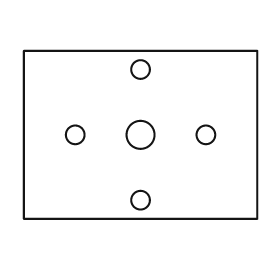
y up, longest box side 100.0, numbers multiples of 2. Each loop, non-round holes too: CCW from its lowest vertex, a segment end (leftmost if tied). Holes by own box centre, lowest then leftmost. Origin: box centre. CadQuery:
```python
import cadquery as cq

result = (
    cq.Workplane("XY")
    .moveTo(-50.0, -36.0)
    .lineTo(50.0, -36.0)
    .lineTo(50.0, 36.0)
    .lineTo(-50.0, 36.0)
    .close()
    .moveTo(0.0, -28.0)
    .circle(4.0)
    .moveTo(-28.0, 0.0)
    .circle(4.0)
    .moveTo(0.0, 0.0)
    .circle(6.0)
    .moveTo(28.0, 0.0)
    .circle(4.0)
    .moveTo(0.0, 28.0)
    .circle(4.0)
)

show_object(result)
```